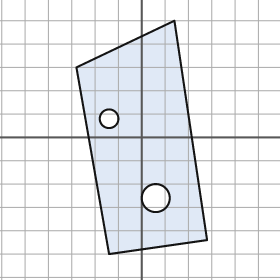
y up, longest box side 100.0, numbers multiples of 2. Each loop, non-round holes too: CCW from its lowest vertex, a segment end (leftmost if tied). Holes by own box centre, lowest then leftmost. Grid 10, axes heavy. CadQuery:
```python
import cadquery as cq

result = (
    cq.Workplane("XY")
    .moveTo(-14.0, -50.0)
    .lineTo(28.0, -44.0)
    .lineTo(14.0, 50.0)
    .lineTo(-28.0, 30.0)
    .close()
    .moveTo(6.0, -26.0)
    .circle(6.0)
    .moveTo(-14.0, 8.0)
    .circle(4.0)
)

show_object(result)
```